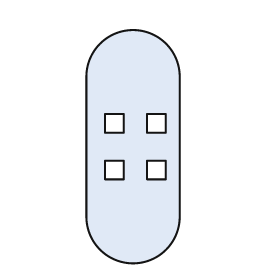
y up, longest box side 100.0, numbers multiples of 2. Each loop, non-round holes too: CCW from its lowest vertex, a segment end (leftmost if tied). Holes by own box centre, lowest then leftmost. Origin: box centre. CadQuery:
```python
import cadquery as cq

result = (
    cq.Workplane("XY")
    .moveTo(-20.0, -30.0)
    .threePointArc((0.0, -50.0), (20.0, -30.0))
    .lineTo(20.0, 30.0)
    .threePointArc((0.0, 50.0), (-20.0, 30.0))
    .close()
    .moveTo(-12.0, -14.0)
    .lineTo(-4.0, -14.0)
    .lineTo(-4.0, -6.0)
    .lineTo(-12.0, -6.0)
    .close()
    .moveTo(6.0, -14.0)
    .lineTo(14.0, -14.0)
    .lineTo(14.0, -6.0)
    .lineTo(6.0, -6.0)
    .close()
    .moveTo(-12.0, 6.0)
    .lineTo(-4.0, 6.0)
    .lineTo(-4.0, 14.0)
    .lineTo(-12.0, 14.0)
    .close()
    .moveTo(6.0, 6.0)
    .lineTo(14.0, 6.0)
    .lineTo(14.0, 14.0)
    .lineTo(6.0, 14.0)
    .close()
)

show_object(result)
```